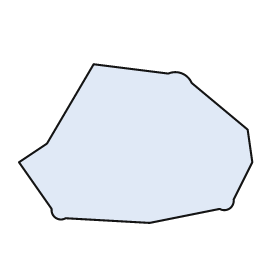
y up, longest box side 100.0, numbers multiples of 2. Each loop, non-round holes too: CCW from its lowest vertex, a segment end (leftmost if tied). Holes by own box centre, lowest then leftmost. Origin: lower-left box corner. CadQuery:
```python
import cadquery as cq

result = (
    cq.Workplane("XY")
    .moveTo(56.0, 0.0)
    .lineTo(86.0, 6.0)
    .threePointArc((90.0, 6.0), (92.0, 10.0))
    .lineTo(100.0, 26.0)
    .lineTo(98.0, 40.0)
    .lineTo(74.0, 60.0)
    .threePointArc((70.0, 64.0), (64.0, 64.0))
    .lineTo(32.0, 68.0)
    .lineTo(12.0, 34.0)
    .lineTo(0.0, 26.0)
    .lineTo(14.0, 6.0)
    .threePointArc((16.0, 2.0), (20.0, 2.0))
    .close()
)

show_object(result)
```